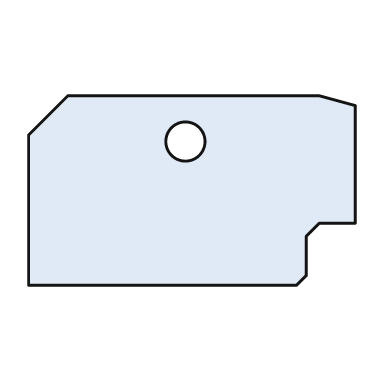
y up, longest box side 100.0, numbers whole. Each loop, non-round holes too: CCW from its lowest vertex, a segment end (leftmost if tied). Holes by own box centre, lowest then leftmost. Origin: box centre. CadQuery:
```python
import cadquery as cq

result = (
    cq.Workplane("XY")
    .moveTo(-50.0, -29.0)
    .lineTo(32.0, -29.0)
    .lineTo(35.0, -26.0)
    .lineTo(35.0, -14.0)
    .lineTo(39.0, -10.0)
    .lineTo(50.0, -10.0)
    .lineTo(50.0, 26.0)
    .lineTo(39.0, 29.0)
    .lineTo(-38.0, 29.0)
    .lineTo(-50.0, 17.0)
    .close()
    .moveTo(-2.0, 15.0)
    .circle(6.0)
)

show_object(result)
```